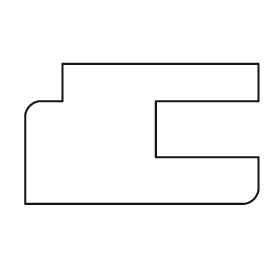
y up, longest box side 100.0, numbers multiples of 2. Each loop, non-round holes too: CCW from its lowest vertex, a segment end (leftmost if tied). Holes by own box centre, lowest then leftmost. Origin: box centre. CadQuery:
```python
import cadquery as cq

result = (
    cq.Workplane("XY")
    .moveTo(-50.0, -30.0)
    .lineTo(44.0, -30.0)
    .threePointArc((48.0, -28.0), (50.0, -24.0))
    .lineTo(50.0, -10.0)
    .lineTo(6.0, -10.0)
    .lineTo(6.0, 14.0)
    .lineTo(50.0, 14.0)
    .lineTo(50.0, 30.0)
    .lineTo(-34.0, 30.0)
    .lineTo(-34.0, 14.0)
    .lineTo(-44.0, 14.0)
    .threePointArc((-48.0, 12.0), (-50.0, 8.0))
    .close()
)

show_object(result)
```